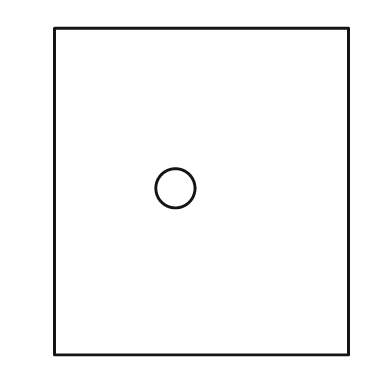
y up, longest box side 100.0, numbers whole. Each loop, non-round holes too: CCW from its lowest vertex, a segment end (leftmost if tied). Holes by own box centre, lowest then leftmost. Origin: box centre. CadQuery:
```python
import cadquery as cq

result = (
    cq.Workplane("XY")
    .moveTo(-45.0, -50.0)
    .lineTo(45.0, -50.0)
    .lineTo(45.0, 50.0)
    .lineTo(-45.0, 50.0)
    .close()
    .moveTo(-8.0, 1.0)
    .circle(6.0)
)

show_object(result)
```